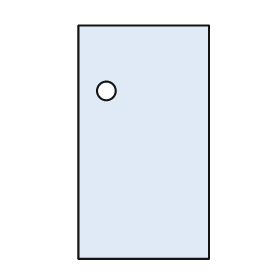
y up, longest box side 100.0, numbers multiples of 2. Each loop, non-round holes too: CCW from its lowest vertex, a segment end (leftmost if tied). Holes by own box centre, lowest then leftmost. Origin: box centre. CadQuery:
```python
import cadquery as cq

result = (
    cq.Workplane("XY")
    .moveTo(-28.0, -50.0)
    .lineTo(28.0, -50.0)
    .lineTo(28.0, 50.0)
    .lineTo(-28.0, 50.0)
    .close()
    .moveTo(-16.0, 22.0)
    .circle(4.0)
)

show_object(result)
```